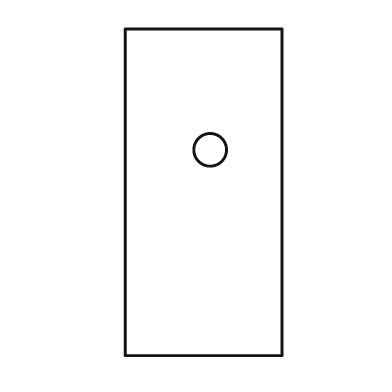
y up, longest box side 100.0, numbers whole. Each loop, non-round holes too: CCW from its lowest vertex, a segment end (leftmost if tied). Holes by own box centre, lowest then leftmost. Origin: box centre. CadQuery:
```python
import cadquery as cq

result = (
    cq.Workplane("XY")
    .moveTo(-24.0, -50.0)
    .lineTo(24.0, -50.0)
    .lineTo(24.0, 50.0)
    .lineTo(-24.0, 50.0)
    .close()
    .moveTo(2.0, 13.0)
    .circle(5.0)
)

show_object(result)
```